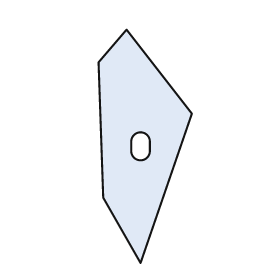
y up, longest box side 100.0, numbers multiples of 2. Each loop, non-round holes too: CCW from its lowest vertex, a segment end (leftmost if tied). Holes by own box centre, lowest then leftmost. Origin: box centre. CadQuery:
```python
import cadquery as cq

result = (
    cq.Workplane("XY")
    .moveTo(-2.0, -50.0)
    .lineTo(20.0, 14.0)
    .lineTo(-8.0, 50.0)
    .lineTo(-20.0, 36.0)
    .lineTo(-18.0, -22.0)
    .close()
    .moveTo(-6.0, -2.0)
    .threePointArc((-2.0, -6.0), (2.0, -2.0))
    .lineTo(2.0, 2.0)
    .threePointArc((-2.0, 6.0), (-6.0, 2.0))
    .close()
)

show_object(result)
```